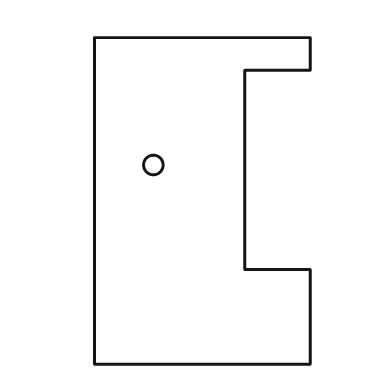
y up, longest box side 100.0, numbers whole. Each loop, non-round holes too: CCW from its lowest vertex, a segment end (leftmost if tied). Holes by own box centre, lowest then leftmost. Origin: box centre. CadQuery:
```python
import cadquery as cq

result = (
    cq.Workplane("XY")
    .moveTo(-33.0, -50.0)
    .lineTo(33.0, -50.0)
    .lineTo(33.0, -21.0)
    .lineTo(13.0, -21.0)
    .lineTo(13.0, 40.0)
    .lineTo(33.0, 40.0)
    .lineTo(33.0, 50.0)
    .lineTo(-33.0, 50.0)
    .close()
    .moveTo(-15.0, 11.0)
    .circle(3.0)
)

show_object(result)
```